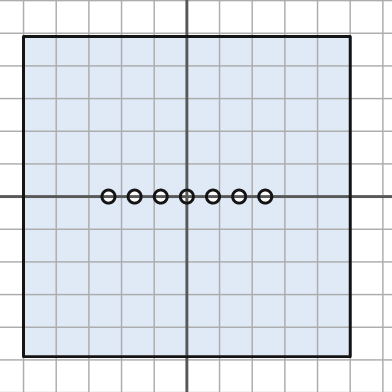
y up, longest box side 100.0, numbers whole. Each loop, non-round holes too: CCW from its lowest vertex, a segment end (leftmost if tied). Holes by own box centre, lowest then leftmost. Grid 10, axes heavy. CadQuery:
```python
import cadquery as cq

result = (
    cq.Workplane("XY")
    .moveTo(-50.0, -49.0)
    .lineTo(50.0, -49.0)
    .lineTo(50.0, 49.0)
    .lineTo(-50.0, 49.0)
    .close()
    .moveTo(-24.0, 0.0)
    .circle(2.0)
    .moveTo(-16.0, 0.0)
    .circle(2.0)
    .moveTo(-8.0, 0.0)
    .circle(2.0)
    .moveTo(0.0, 0.0)
    .circle(2.0)
    .moveTo(8.0, 0.0)
    .circle(2.0)
    .moveTo(16.0, 0.0)
    .circle(2.0)
    .moveTo(24.0, 0.0)
    .circle(2.0)
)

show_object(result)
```